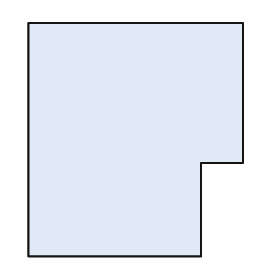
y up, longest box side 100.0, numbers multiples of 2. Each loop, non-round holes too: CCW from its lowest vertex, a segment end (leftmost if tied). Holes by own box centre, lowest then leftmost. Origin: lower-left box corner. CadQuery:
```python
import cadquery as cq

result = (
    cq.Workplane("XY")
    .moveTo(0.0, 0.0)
    .lineTo(74.0, 0.0)
    .lineTo(74.0, 40.0)
    .lineTo(92.0, 40.0)
    .lineTo(92.0, 100.0)
    .lineTo(0.0, 100.0)
    .close()
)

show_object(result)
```